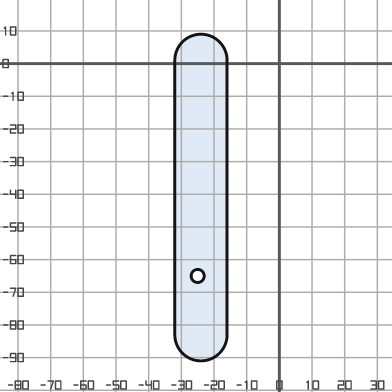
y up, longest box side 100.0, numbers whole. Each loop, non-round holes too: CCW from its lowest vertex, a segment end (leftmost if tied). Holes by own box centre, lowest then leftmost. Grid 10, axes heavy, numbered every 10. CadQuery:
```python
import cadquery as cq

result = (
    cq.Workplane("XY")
    .moveTo(-32.0, -83.0)
    .threePointArc((-24.0, -91.0), (-16.0, -83.0))
    .lineTo(-16.0, 1.0)
    .threePointArc((-24.0, 9.0), (-32.0, 1.0))
    .close()
    .moveTo(-25.0, -65.0)
    .circle(2.0)
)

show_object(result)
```